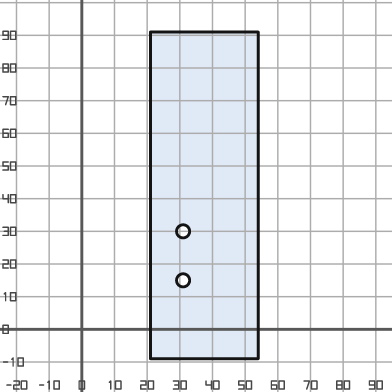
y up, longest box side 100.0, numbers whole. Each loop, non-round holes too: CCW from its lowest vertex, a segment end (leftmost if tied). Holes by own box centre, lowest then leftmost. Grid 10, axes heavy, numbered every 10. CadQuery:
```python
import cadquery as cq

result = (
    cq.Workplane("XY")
    .moveTo(21.0, -9.0)
    .lineTo(54.0, -9.0)
    .lineTo(54.0, 91.0)
    .lineTo(21.0, 91.0)
    .close()
    .moveTo(31.0, 15.0)
    .circle(2.0)
    .moveTo(31.0, 30.0)
    .circle(2.0)
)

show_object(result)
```